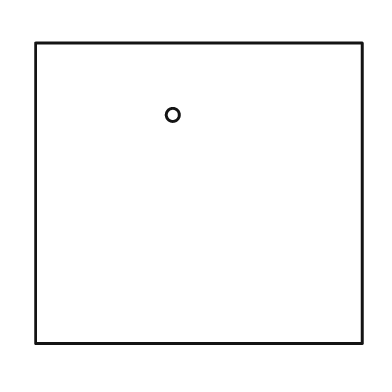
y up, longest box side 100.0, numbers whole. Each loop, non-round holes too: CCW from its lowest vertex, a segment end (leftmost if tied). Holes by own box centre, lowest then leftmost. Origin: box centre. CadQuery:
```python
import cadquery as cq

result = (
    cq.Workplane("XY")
    .moveTo(-50.0, -46.0)
    .lineTo(50.0, -46.0)
    .lineTo(50.0, 46.0)
    .lineTo(-50.0, 46.0)
    .close()
    .moveTo(-8.0, 24.0)
    .circle(2.0)
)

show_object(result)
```